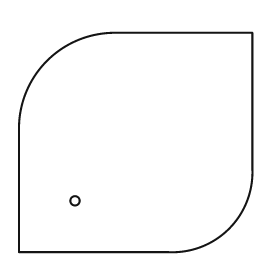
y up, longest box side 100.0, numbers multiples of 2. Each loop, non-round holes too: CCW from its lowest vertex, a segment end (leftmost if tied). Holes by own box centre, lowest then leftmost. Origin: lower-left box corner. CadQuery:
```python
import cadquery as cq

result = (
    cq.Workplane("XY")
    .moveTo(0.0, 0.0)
    .lineTo(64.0, 0.0)
    .threePointArc((90.0, 10.0), (100.0, 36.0))
    .lineTo(100.0, 94.0)
    .lineTo(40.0, 94.0)
    .threePointArc((12.0, 82.0), (0.0, 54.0))
    .close()
    .moveTo(24.0, 22.0)
    .circle(2.0)
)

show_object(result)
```